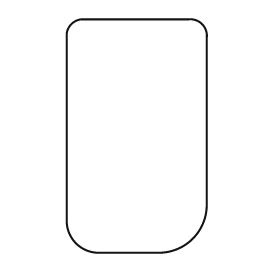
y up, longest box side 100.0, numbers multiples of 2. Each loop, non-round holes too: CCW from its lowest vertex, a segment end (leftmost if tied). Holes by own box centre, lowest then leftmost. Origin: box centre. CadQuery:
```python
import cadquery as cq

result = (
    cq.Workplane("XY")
    .moveTo(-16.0, -50.0)
    .lineTo(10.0, -50.0)
    .threePointArc((24.0, -44.0), (30.0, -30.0))
    .lineTo(30.0, 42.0)
    .threePointArc((28.0, 48.0), (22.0, 50.0))
    .lineTo(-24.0, 50.0)
    .threePointArc((-28.0, 48.0), (-30.0, 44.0))
    .lineTo(-30.0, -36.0)
    .threePointArc((-26.0, -46.0), (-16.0, -50.0))
    .close()
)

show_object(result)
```